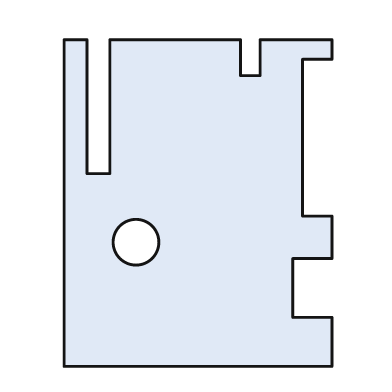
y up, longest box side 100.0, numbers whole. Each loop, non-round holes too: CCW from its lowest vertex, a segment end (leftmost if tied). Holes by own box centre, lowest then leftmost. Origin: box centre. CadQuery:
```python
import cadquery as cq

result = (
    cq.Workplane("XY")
    .moveTo(-41.0, -50.0)
    .lineTo(41.0, -50.0)
    .lineTo(41.0, -35.0)
    .lineTo(29.0, -35.0)
    .lineTo(29.0, -17.0)
    .lineTo(41.0, -17.0)
    .lineTo(41.0, -4.0)
    .lineTo(32.0, -4.0)
    .lineTo(32.0, 44.0)
    .lineTo(41.0, 44.0)
    .lineTo(41.0, 50.0)
    .lineTo(19.0, 50.0)
    .lineTo(19.0, 39.0)
    .lineTo(13.0, 39.0)
    .lineTo(13.0, 50.0)
    .lineTo(-27.0, 50.0)
    .lineTo(-27.0, 9.0)
    .lineTo(-34.0, 9.0)
    .lineTo(-34.0, 50.0)
    .lineTo(-41.0, 50.0)
    .close()
    .moveTo(-19.0, -12.0)
    .circle(7.0)
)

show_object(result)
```